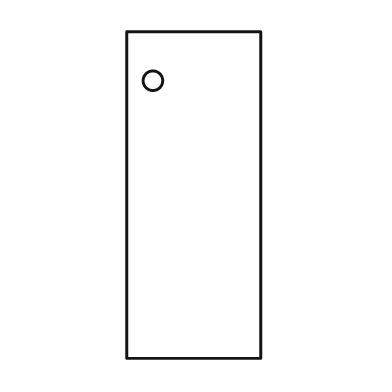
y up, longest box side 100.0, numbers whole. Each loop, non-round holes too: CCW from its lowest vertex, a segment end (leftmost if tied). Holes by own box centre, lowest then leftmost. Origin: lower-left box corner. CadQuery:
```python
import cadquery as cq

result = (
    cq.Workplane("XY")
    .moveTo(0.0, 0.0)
    .lineTo(41.0, 0.0)
    .lineTo(41.0, 100.0)
    .lineTo(0.0, 100.0)
    .close()
    .moveTo(8.0, 85.0)
    .circle(3.0)
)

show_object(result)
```